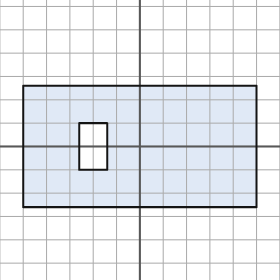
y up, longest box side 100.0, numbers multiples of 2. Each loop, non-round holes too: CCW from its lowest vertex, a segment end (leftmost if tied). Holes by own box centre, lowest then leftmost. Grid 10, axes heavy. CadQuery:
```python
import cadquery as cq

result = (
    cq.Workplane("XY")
    .moveTo(-50.0, -26.0)
    .lineTo(50.0, -26.0)
    .lineTo(50.0, 26.0)
    .lineTo(-50.0, 26.0)
    .close()
    .moveTo(-26.0, -10.0)
    .lineTo(-14.0, -10.0)
    .lineTo(-14.0, 10.0)
    .lineTo(-26.0, 10.0)
    .close()
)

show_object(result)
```